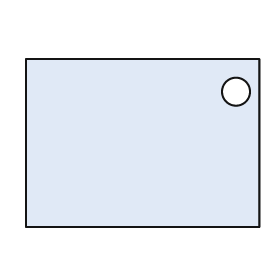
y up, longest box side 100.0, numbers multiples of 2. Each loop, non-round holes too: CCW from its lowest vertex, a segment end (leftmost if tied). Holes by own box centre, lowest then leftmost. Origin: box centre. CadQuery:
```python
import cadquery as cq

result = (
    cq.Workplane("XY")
    .moveTo(-50.0, -36.0)
    .lineTo(50.0, -36.0)
    .lineTo(50.0, 36.0)
    .lineTo(-50.0, 36.0)
    .close()
    .moveTo(40.0, 22.0)
    .circle(6.0)
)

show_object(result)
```